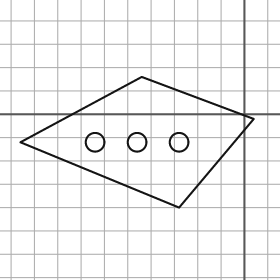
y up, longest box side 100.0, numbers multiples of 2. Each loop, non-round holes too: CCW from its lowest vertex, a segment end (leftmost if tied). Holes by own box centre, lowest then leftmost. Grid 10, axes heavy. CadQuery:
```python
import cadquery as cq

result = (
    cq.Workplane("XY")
    .moveTo(-28.0, -40.0)
    .lineTo(4.0, -2.0)
    .lineTo(-44.0, 16.0)
    .lineTo(-96.0, -12.0)
    .close()
    .moveTo(-64.0, -12.0)
    .circle(4.0)
    .moveTo(-46.0, -12.0)
    .circle(4.0)
    .moveTo(-28.0, -12.0)
    .circle(4.0)
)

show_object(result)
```